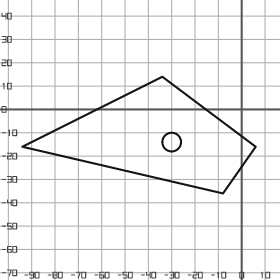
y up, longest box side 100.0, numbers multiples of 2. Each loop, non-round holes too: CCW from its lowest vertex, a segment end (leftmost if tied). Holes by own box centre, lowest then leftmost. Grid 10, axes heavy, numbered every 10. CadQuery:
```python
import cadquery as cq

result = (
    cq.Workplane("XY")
    .moveTo(-8.0, -36.0)
    .lineTo(6.0, -16.0)
    .lineTo(-34.0, 14.0)
    .lineTo(-94.0, -16.0)
    .close()
    .moveTo(-30.0, -14.0)
    .circle(4.0)
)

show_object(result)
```